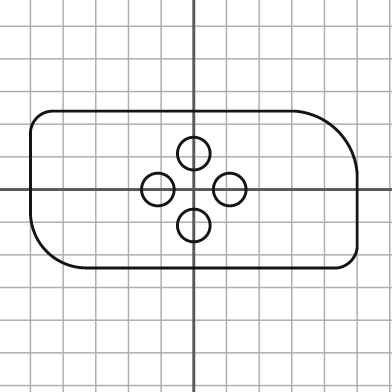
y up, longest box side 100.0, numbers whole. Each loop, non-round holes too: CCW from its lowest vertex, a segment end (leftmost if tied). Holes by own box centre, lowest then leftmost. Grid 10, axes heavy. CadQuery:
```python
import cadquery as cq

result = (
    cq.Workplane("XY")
    .moveTo(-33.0, -24.0)
    .lineTo(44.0, -24.0)
    .threePointArc((48.0, -22.0), (50.0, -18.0))
    .lineTo(50.0, 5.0)
    .threePointArc((44.0, 18.0), (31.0, 24.0))
    .lineTo(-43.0, 24.0)
    .threePointArc((-48.0, 22.0), (-50.0, 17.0))
    .lineTo(-50.0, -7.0)
    .threePointArc((-45.0, -19.0), (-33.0, -24.0))
    .close()
    .moveTo(0.0, -11.0)
    .circle(5.0)
    .moveTo(-11.0, 0.0)
    .circle(5.0)
    .moveTo(11.0, 0.0)
    .circle(5.0)
    .moveTo(0.0, 11.0)
    .circle(5.0)
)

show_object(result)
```